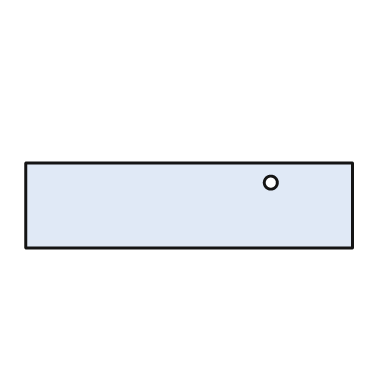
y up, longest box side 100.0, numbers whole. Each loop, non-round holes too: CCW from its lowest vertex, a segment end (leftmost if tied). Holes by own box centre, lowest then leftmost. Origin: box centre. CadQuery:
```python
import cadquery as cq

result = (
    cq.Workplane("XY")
    .moveTo(-50.0, -13.0)
    .lineTo(50.0, -13.0)
    .lineTo(50.0, 13.0)
    .lineTo(-50.0, 13.0)
    .close()
    .moveTo(25.0, 7.0)
    .circle(2.0)
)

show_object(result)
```